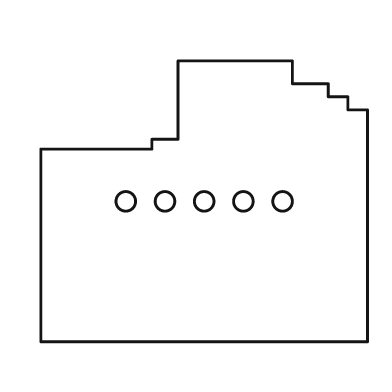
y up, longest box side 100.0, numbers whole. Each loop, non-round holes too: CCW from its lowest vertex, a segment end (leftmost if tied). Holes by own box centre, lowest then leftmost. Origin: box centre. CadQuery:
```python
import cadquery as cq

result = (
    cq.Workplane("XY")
    .moveTo(-50.0, -43.0)
    .lineTo(50.0, -43.0)
    .lineTo(50.0, 28.0)
    .lineTo(44.0, 28.0)
    .lineTo(44.0, 32.0)
    .lineTo(38.0, 32.0)
    .lineTo(38.0, 36.0)
    .lineTo(27.0, 36.0)
    .lineTo(27.0, 43.0)
    .lineTo(-8.0, 43.0)
    .lineTo(-8.0, 19.0)
    .lineTo(-16.0, 19.0)
    .lineTo(-16.0, 16.0)
    .lineTo(-50.0, 16.0)
    .close()
    .moveTo(-24.0, 0.0)
    .circle(3.0)
    .moveTo(-12.0, 0.0)
    .circle(3.0)
    .moveTo(0.0, 0.0)
    .circle(3.0)
    .moveTo(12.0, 0.0)
    .circle(3.0)
    .moveTo(24.0, 0.0)
    .circle(3.0)
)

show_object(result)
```